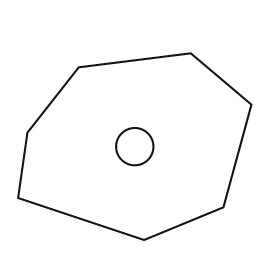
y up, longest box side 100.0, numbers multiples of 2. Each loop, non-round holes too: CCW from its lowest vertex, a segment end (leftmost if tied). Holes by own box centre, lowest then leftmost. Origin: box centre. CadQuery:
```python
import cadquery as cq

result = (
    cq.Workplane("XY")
    .moveTo(4.0, -40.0)
    .lineTo(38.0, -26.0)
    .lineTo(50.0, 18.0)
    .lineTo(24.0, 40.0)
    .lineTo(-24.0, 34.0)
    .lineTo(-46.0, 6.0)
    .lineTo(-50.0, -22.0)
    .close()
    .moveTo(0.0, 0.0)
    .circle(8.0)
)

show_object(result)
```